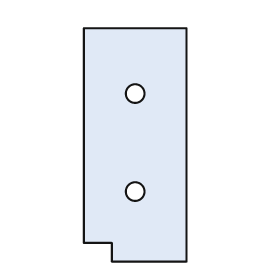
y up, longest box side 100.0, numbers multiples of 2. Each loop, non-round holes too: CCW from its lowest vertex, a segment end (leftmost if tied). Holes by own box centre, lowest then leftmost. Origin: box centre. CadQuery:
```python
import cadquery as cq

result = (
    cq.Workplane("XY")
    .moveTo(-10.0, -50.0)
    .lineTo(22.0, -50.0)
    .lineTo(22.0, 50.0)
    .lineTo(-22.0, 50.0)
    .lineTo(-22.0, -42.0)
    .lineTo(-10.0, -42.0)
    .close()
    .moveTo(0.0, -20.0)
    .circle(4.0)
    .moveTo(0.0, 22.0)
    .circle(4.0)
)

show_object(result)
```